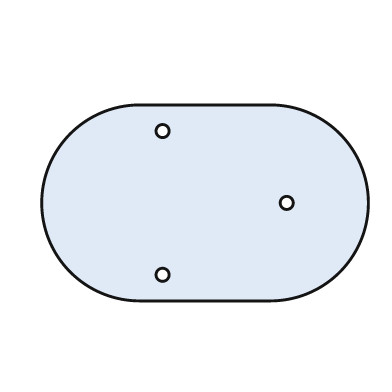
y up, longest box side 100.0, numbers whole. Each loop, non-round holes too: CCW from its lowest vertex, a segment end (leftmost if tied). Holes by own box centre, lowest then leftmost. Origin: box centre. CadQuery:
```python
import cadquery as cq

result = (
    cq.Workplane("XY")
    .moveTo(-20.0, -30.0)
    .lineTo(20.0, -30.0)
    .threePointArc((50.0, 0.0), (20.0, 30.0))
    .lineTo(-20.0, 30.0)
    .threePointArc((-50.0, 0.0), (-20.0, -30.0))
    .close()
    .moveTo(-13.0, -22.0)
    .circle(2.0)
    .moveTo(25.0, 0.0)
    .circle(2.0)
    .moveTo(-13.0, 22.0)
    .circle(2.0)
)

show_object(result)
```